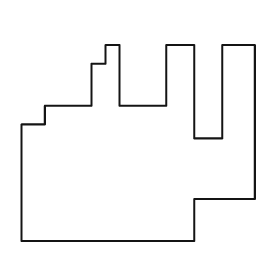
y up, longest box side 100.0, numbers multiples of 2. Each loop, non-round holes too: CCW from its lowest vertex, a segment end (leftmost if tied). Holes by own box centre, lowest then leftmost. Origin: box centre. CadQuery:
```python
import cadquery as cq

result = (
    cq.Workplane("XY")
    .moveTo(-50.0, -42.0)
    .lineTo(24.0, -42.0)
    .lineTo(24.0, -24.0)
    .lineTo(50.0, -24.0)
    .lineTo(50.0, 42.0)
    .lineTo(36.0, 42.0)
    .lineTo(36.0, 2.0)
    .lineTo(24.0, 2.0)
    .lineTo(24.0, 42.0)
    .lineTo(12.0, 42.0)
    .lineTo(12.0, 16.0)
    .lineTo(-8.0, 16.0)
    .lineTo(-8.0, 42.0)
    .lineTo(-14.0, 42.0)
    .lineTo(-14.0, 34.0)
    .lineTo(-20.0, 34.0)
    .lineTo(-20.0, 16.0)
    .lineTo(-40.0, 16.0)
    .lineTo(-40.0, 8.0)
    .lineTo(-50.0, 8.0)
    .close()
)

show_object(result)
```